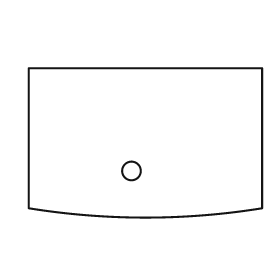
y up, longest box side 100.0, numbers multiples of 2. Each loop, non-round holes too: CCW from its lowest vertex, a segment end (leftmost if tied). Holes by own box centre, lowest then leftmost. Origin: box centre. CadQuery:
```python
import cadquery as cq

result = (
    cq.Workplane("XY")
    .moveTo(-50.0, -28.0)
    .threePointArc((0.0, -32.0), (50.0, -28.0))
    .lineTo(50.0, 32.0)
    .lineTo(-50.0, 32.0)
    .close()
    .moveTo(-6.0, -12.0)
    .circle(4.0)
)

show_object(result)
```